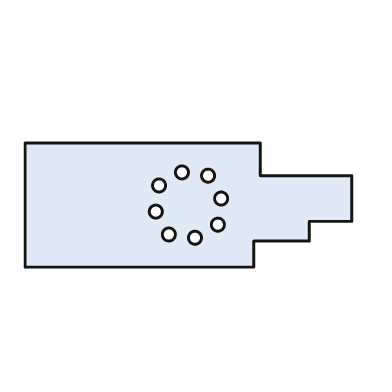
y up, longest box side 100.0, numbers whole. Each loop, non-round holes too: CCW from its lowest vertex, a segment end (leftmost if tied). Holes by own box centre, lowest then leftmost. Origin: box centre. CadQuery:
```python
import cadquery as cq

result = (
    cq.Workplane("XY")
    .moveTo(-50.0, -19.0)
    .lineTo(20.0, -19.0)
    .lineTo(20.0, -11.0)
    .lineTo(37.0, -11.0)
    .lineTo(37.0, -5.0)
    .lineTo(50.0, -5.0)
    .lineTo(50.0, 9.0)
    .lineTo(22.0, 9.0)
    .lineTo(22.0, 19.0)
    .lineTo(-50.0, 19.0)
    .close()
    .moveTo(2.0, -10.0)
    .circle(2.0)
    .moveTo(-6.0, -9.0)
    .circle(2.0)
    .moveTo(9.0, -6.0)
    .circle(2.0)
    .moveTo(-10.0, -2.0)
    .circle(2.0)
    .moveTo(10.0, 2.0)
    .circle(2.0)
    .moveTo(-9.0, 6.0)
    .circle(2.0)
    .moveTo(6.0, 9.0)
    .circle(2.0)
    .moveTo(-2.0, 10.0)
    .circle(2.0)
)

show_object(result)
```